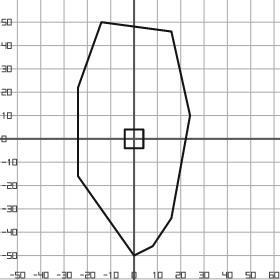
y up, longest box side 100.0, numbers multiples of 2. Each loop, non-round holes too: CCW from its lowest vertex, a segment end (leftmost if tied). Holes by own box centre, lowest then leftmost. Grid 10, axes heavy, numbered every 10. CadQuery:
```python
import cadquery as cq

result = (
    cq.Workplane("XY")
    .moveTo(0.0, -50.0)
    .lineTo(8.0, -46.0)
    .lineTo(16.0, -34.0)
    .lineTo(24.0, 10.0)
    .lineTo(16.0, 46.0)
    .lineTo(-14.0, 50.0)
    .lineTo(-24.0, 22.0)
    .lineTo(-24.0, -16.0)
    .close()
    .moveTo(-4.0, -4.0)
    .lineTo(4.0, -4.0)
    .lineTo(4.0, 4.0)
    .lineTo(-4.0, 4.0)
    .close()
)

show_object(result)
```